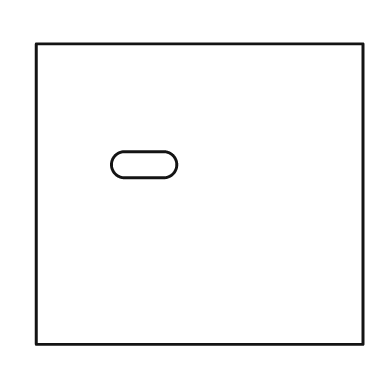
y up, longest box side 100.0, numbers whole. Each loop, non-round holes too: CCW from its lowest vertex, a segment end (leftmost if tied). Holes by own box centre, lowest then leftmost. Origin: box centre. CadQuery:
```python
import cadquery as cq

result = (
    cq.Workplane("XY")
    .moveTo(-50.0, -46.0)
    .lineTo(50.0, -46.0)
    .lineTo(50.0, 46.0)
    .lineTo(-50.0, 46.0)
    .close()
    .moveTo(-23.0, 5.0)
    .lineTo(-11.0, 5.0)
    .threePointArc((-7.0, 9.0), (-11.0, 13.0))
    .lineTo(-23.0, 13.0)
    .threePointArc((-27.0, 9.0), (-23.0, 5.0))
    .close()
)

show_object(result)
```